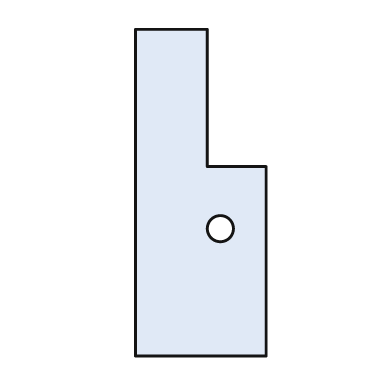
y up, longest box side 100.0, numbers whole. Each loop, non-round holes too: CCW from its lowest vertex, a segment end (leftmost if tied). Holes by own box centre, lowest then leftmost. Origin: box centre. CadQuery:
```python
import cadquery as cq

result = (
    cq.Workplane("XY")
    .moveTo(-20.0, -50.0)
    .lineTo(20.0, -50.0)
    .lineTo(20.0, 8.0)
    .lineTo(2.0, 8.0)
    .lineTo(2.0, 50.0)
    .lineTo(-20.0, 50.0)
    .close()
    .moveTo(6.0, -11.0)
    .circle(4.0)
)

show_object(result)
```